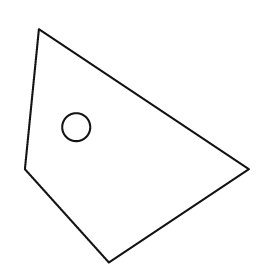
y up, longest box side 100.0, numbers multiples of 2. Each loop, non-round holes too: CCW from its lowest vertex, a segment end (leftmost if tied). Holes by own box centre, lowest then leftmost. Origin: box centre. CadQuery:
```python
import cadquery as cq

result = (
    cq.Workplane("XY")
    .moveTo(-12.0, -50.0)
    .lineTo(48.0, -10.0)
    .lineTo(-42.0, 50.0)
    .lineTo(-48.0, -10.0)
    .close()
    .moveTo(-26.0, 8.0)
    .circle(6.0)
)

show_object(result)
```